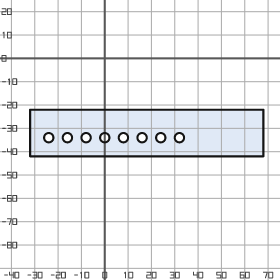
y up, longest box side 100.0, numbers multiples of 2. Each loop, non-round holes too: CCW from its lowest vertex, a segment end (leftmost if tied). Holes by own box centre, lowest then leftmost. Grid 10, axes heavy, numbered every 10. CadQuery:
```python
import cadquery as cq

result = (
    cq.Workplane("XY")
    .moveTo(-32.0, -42.0)
    .lineTo(68.0, -42.0)
    .lineTo(68.0, -22.0)
    .lineTo(-32.0, -22.0)
    .close()
    .moveTo(-24.0, -34.0)
    .circle(2.0)
    .moveTo(-16.0, -34.0)
    .circle(2.0)
    .moveTo(-8.0, -34.0)
    .circle(2.0)
    .moveTo(0.0, -34.0)
    .circle(2.0)
    .moveTo(8.0, -34.0)
    .circle(2.0)
    .moveTo(16.0, -34.0)
    .circle(2.0)
    .moveTo(24.0, -34.0)
    .circle(2.0)
    .moveTo(32.0, -34.0)
    .circle(2.0)
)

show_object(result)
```